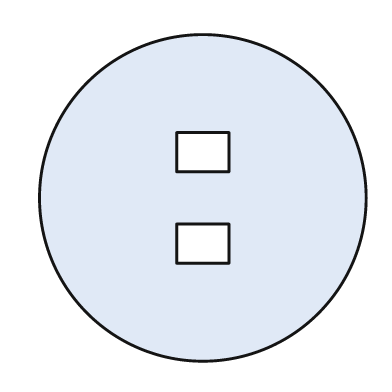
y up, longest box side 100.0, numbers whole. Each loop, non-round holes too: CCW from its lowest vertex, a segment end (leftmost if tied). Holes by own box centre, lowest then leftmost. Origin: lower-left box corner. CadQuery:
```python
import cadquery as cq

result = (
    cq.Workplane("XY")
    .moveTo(50.0, 50.0)
    .circle(50.0)
    .moveTo(42.0, 30.0)
    .lineTo(58.0, 30.0)
    .lineTo(58.0, 42.0)
    .lineTo(42.0, 42.0)
    .close()
    .moveTo(42.0, 58.0)
    .lineTo(58.0, 58.0)
    .lineTo(58.0, 70.0)
    .lineTo(42.0, 70.0)
    .close()
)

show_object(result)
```